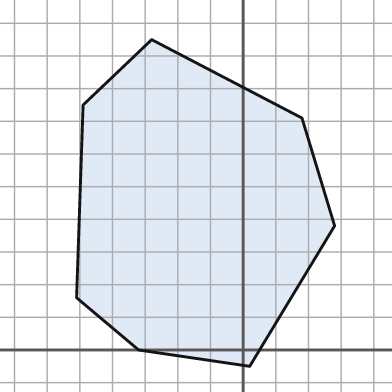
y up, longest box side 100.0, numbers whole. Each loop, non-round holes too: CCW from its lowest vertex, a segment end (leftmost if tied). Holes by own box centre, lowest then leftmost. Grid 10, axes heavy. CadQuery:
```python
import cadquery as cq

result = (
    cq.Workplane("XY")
    .moveTo(2.0, -5.0)
    .lineTo(28.0, 38.0)
    .lineTo(18.0, 71.0)
    .lineTo(-28.0, 95.0)
    .lineTo(-49.0, 75.0)
    .lineTo(-51.0, 16.0)
    .lineTo(-32.0, 0.0)
    .close()
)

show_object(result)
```